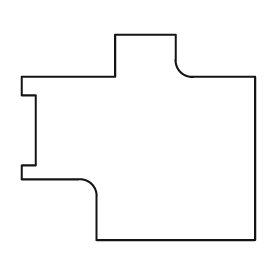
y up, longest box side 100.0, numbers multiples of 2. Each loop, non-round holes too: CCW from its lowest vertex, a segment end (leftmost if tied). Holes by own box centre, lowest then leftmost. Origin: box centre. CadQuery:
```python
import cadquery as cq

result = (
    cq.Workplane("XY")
    .moveTo(-18.0, -44.0)
    .lineTo(50.0, -44.0)
    .lineTo(50.0, 26.0)
    .lineTo(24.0, 26.0)
    .threePointArc((18.0, 28.0), (16.0, 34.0))
    .lineTo(16.0, 44.0)
    .lineTo(-10.0, 44.0)
    .lineTo(-10.0, 26.0)
    .lineTo(-50.0, 26.0)
    .lineTo(-50.0, 18.0)
    .lineTo(-44.0, 18.0)
    .lineTo(-44.0, -12.0)
    .lineTo(-50.0, -12.0)
    .lineTo(-50.0, -18.0)
    .lineTo(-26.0, -18.0)
    .threePointArc((-20.0, -20.0), (-18.0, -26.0))
    .close()
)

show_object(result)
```